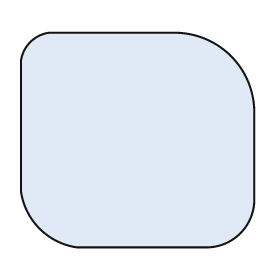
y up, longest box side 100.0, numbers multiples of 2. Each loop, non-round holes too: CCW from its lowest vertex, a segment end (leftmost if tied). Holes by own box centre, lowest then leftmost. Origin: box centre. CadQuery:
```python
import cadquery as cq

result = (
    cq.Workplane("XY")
    .moveTo(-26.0, -46.0)
    .lineTo(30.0, -46.0)
    .threePointArc((44.0, -40.0), (50.0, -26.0))
    .lineTo(50.0, 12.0)
    .threePointArc((40.0, 36.0), (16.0, 46.0))
    .lineTo(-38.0, 46.0)
    .threePointArc((-46.0, 42.0), (-50.0, 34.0))
    .lineTo(-50.0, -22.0)
    .threePointArc((-42.0, -38.0), (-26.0, -46.0))
    .close()
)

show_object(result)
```